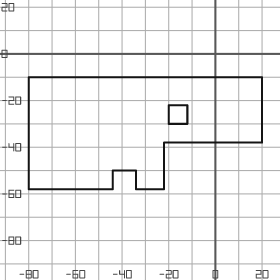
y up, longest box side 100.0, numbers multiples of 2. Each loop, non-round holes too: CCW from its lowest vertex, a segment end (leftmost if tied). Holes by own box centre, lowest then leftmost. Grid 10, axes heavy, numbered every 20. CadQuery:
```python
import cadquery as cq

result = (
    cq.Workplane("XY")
    .moveTo(-80.0, -58.0)
    .lineTo(-44.0, -58.0)
    .lineTo(-44.0, -50.0)
    .lineTo(-34.0, -50.0)
    .lineTo(-34.0, -58.0)
    .lineTo(-22.0, -58.0)
    .lineTo(-22.0, -38.0)
    .lineTo(20.0, -38.0)
    .lineTo(20.0, -10.0)
    .lineTo(-80.0, -10.0)
    .close()
    .moveTo(-20.0, -30.0)
    .lineTo(-12.0, -30.0)
    .lineTo(-12.0, -22.0)
    .lineTo(-20.0, -22.0)
    .close()
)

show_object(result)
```